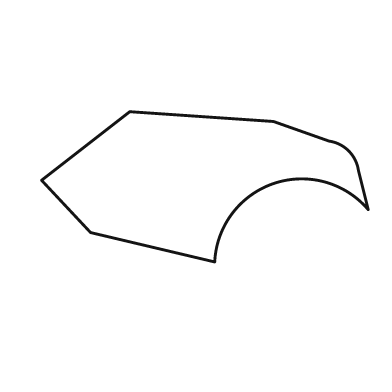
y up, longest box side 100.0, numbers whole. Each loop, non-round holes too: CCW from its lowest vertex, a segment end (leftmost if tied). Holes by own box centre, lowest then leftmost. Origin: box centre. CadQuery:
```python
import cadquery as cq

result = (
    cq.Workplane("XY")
    .moveTo(3.0, -23.0)
    .threePointArc((21.0, 1.0), (50.0, -7.0))
    .lineTo(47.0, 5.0)
    .threePointArc((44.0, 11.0), (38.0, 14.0))
    .lineTo(21.0, 20.0)
    .lineTo(-23.0, 23.0)
    .lineTo(-50.0, 2.0)
    .lineTo(-35.0, -14.0)
    .close()
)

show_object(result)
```